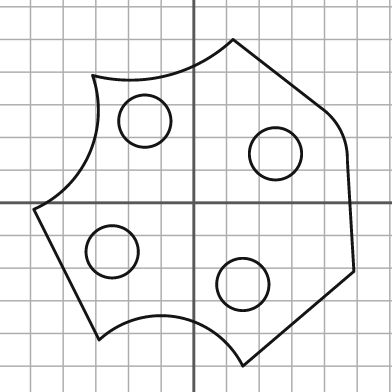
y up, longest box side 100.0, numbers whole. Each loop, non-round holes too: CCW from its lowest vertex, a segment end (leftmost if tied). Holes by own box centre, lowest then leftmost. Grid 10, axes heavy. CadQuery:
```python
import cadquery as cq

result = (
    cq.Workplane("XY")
    .moveTo(15.0, -50.0)
    .lineTo(49.0, -21.0)
    .lineTo(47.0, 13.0)
    .threePointArc((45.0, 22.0), (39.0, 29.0))
    .lineTo(12.0, 50.0)
    .threePointArc((-8.0, 39.0), (-31.0, 39.0))
    .threePointArc((-32.0, 15.0), (-49.0, -2.0))
    .lineTo(-29.0, -42.0)
    .threePointArc((-5.0, -35.0), (15.0, -50.0))
    .close()
    .moveTo(15.0, -25.0)
    .circle(8.0)
    .moveTo(-25.0, -15.0)
    .circle(8.0)
    .moveTo(25.0, 15.0)
    .circle(8.0)
    .moveTo(-15.0, 25.0)
    .circle(8.0)
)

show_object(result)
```